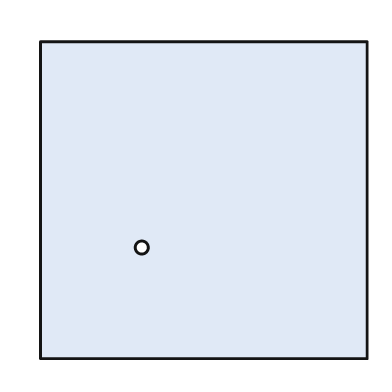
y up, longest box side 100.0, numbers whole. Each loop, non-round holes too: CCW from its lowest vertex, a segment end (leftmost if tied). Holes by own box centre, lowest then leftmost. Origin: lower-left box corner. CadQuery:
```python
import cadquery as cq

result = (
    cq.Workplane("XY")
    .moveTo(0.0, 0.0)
    .lineTo(100.0, 0.0)
    .lineTo(100.0, 97.0)
    .lineTo(0.0, 97.0)
    .close()
    .moveTo(31.0, 34.0)
    .circle(2.0)
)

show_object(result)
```